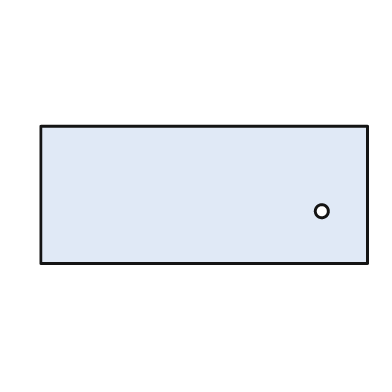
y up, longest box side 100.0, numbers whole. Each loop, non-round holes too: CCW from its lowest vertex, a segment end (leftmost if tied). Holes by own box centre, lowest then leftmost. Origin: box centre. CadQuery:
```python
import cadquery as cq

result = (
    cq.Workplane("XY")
    .moveTo(-50.0, -21.0)
    .lineTo(50.0, -21.0)
    .lineTo(50.0, 21.0)
    .lineTo(-50.0, 21.0)
    .close()
    .moveTo(36.0, -5.0)
    .circle(2.0)
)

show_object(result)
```